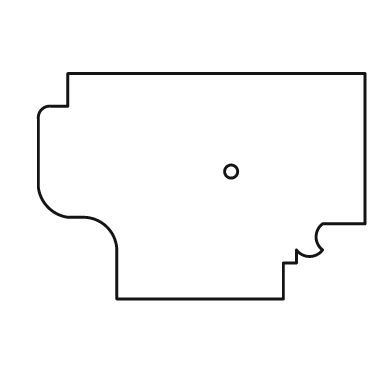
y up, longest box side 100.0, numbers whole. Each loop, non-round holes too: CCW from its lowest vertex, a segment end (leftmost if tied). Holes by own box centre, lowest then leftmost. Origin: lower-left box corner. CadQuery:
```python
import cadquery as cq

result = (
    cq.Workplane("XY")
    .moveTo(24.0, 0.0)
    .lineTo(75.0, 0.0)
    .lineTo(75.0, 11.0)
    .lineTo(79.0, 11.0)
    .lineTo(79.0, 15.0)
    .threePointArc((83.0, 13.0), (87.0, 15.0))
    .threePointArc((85.0, 19.0), (87.0, 23.0))
    .lineTo(100.0, 23.0)
    .lineTo(100.0, 69.0)
    .lineTo(9.0, 69.0)
    .lineTo(9.0, 59.0)
    .lineTo(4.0, 59.0)
    .threePointArc((1.0, 58.0), (0.0, 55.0))
    .lineTo(0.0, 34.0)
    .threePointArc((3.0, 28.0), (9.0, 25.0))
    .lineTo(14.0, 25.0)
    .threePointArc((21.0, 22.0), (24.0, 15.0))
    .close()
    .moveTo(59.0, 39.0)
    .circle(2.0)
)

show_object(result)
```